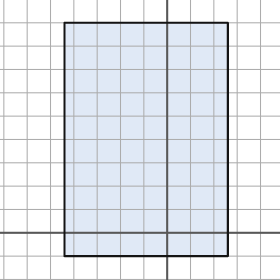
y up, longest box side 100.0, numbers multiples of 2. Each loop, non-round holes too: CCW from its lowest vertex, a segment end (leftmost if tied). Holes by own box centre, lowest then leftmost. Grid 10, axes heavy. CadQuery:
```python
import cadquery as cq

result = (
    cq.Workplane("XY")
    .moveTo(-44.0, -10.0)
    .lineTo(26.0, -10.0)
    .lineTo(26.0, 90.0)
    .lineTo(-44.0, 90.0)
    .close()
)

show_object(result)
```